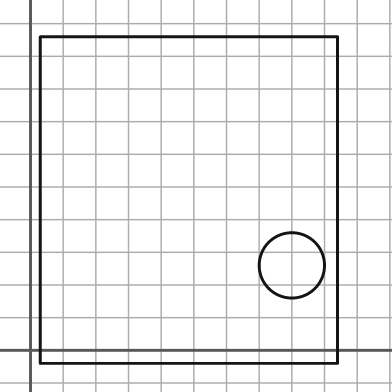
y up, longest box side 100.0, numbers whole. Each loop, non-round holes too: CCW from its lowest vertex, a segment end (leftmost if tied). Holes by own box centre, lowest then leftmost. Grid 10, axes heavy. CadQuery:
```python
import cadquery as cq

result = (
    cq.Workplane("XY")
    .moveTo(3.0, -4.0)
    .lineTo(94.0, -4.0)
    .lineTo(94.0, 96.0)
    .lineTo(3.0, 96.0)
    .close()
    .moveTo(80.0, 26.0)
    .circle(10.0)
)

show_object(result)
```